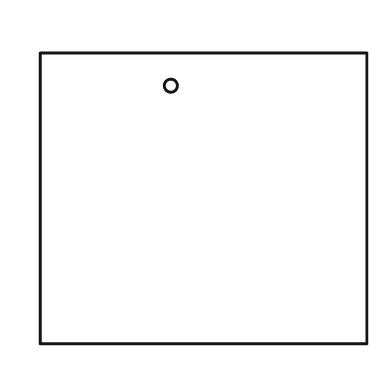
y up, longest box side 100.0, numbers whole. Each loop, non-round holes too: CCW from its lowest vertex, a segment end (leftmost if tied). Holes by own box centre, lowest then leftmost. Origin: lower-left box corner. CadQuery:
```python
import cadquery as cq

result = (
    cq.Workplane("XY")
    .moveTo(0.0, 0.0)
    .lineTo(100.0, 0.0)
    .lineTo(100.0, 89.0)
    .lineTo(0.0, 89.0)
    .close()
    .moveTo(40.0, 79.0)
    .circle(2.0)
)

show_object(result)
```